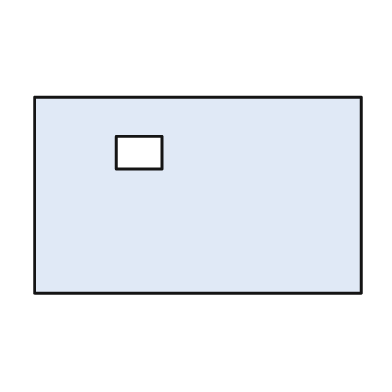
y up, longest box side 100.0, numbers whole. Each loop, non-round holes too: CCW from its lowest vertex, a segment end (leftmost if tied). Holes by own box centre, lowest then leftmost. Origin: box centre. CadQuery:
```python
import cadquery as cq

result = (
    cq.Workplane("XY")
    .moveTo(-50.0, -30.0)
    .lineTo(50.0, -30.0)
    .lineTo(50.0, 30.0)
    .lineTo(-50.0, 30.0)
    .close()
    .moveTo(-25.0, 8.0)
    .lineTo(-11.0, 8.0)
    .lineTo(-11.0, 18.0)
    .lineTo(-25.0, 18.0)
    .close()
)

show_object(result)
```